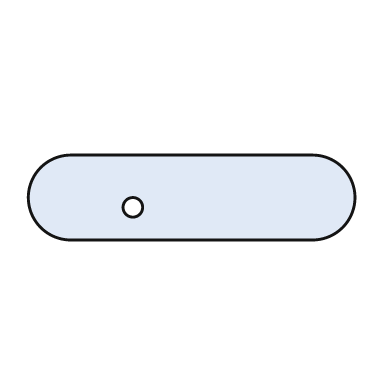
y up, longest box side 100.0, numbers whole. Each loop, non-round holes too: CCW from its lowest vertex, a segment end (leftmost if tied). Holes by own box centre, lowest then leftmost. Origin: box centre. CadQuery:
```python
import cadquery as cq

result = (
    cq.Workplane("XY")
    .moveTo(-37.0, -13.0)
    .lineTo(37.0, -13.0)
    .threePointArc((50.0, 0.0), (37.0, 13.0))
    .lineTo(-37.0, 13.0)
    .threePointArc((-50.0, 0.0), (-37.0, -13.0))
    .close()
    .moveTo(-18.0, -3.0)
    .circle(3.0)
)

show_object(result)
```